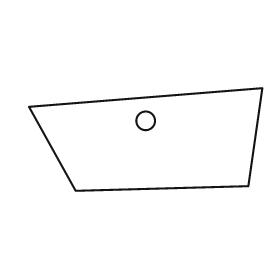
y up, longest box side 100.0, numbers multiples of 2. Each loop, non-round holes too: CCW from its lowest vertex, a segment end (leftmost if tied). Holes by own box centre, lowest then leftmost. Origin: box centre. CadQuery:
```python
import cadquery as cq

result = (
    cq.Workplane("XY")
    .moveTo(-30.0, -22.0)
    .lineTo(44.0, -20.0)
    .lineTo(50.0, 22.0)
    .lineTo(-50.0, 14.0)
    .close()
    .moveTo(0.0, 8.0)
    .circle(4.0)
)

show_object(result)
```